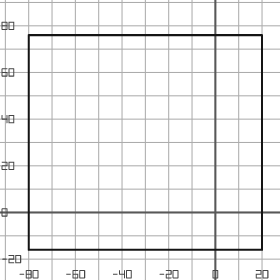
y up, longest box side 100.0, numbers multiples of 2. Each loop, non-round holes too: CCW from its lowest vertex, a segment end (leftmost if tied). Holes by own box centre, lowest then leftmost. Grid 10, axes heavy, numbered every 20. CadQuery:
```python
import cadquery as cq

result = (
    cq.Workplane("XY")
    .moveTo(-80.0, -16.0)
    .lineTo(20.0, -16.0)
    .lineTo(20.0, 76.0)
    .lineTo(-80.0, 76.0)
    .close()
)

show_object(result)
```